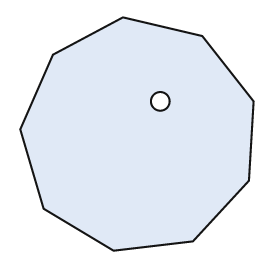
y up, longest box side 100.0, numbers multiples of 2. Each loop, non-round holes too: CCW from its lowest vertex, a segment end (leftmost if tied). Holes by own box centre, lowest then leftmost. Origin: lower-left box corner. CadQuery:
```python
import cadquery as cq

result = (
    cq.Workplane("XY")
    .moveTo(40.0, 0.0)
    .lineTo(74.0, 4.0)
    .lineTo(98.0, 30.0)
    .lineTo(100.0, 64.0)
    .lineTo(78.0, 92.0)
    .lineTo(44.0, 100.0)
    .lineTo(14.0, 84.0)
    .lineTo(0.0, 52.0)
    .lineTo(10.0, 18.0)
    .close()
    .moveTo(60.0, 64.0)
    .circle(4.0)
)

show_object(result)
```